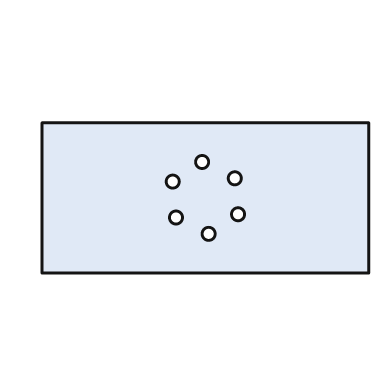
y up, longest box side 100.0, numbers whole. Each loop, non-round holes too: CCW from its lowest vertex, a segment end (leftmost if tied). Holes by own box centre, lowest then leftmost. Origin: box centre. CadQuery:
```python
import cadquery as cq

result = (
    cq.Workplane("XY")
    .moveTo(-50.0, -23.0)
    .lineTo(50.0, -23.0)
    .lineTo(50.0, 23.0)
    .lineTo(-50.0, 23.0)
    .close()
    .moveTo(1.0, -11.0)
    .circle(2.0)
    .moveTo(-9.0, -6.0)
    .circle(2.0)
    .moveTo(10.0, -5.0)
    .circle(2.0)
    .moveTo(-10.0, 5.0)
    .circle(2.0)
    .moveTo(9.0, 6.0)
    .circle(2.0)
    .moveTo(-1.0, 11.0)
    .circle(2.0)
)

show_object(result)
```